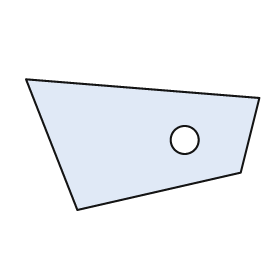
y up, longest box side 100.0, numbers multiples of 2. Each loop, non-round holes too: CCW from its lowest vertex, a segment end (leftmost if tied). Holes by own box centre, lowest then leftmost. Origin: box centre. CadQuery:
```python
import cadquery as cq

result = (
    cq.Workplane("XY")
    .moveTo(-28.0, -28.0)
    .lineTo(42.0, -12.0)
    .lineTo(50.0, 20.0)
    .lineTo(-50.0, 28.0)
    .close()
    .moveTo(18.0, 2.0)
    .circle(6.0)
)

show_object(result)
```